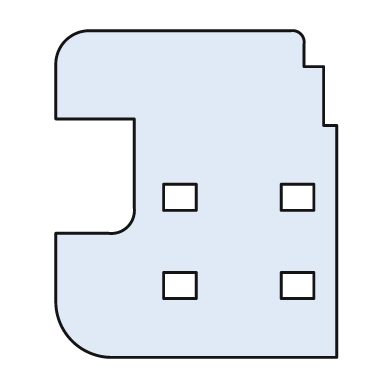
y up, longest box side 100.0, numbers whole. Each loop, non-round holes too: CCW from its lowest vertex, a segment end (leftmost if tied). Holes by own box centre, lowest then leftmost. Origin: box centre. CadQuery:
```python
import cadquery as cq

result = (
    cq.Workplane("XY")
    .moveTo(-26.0, -50.0)
    .lineTo(43.0, -50.0)
    .lineTo(43.0, 21.0)
    .lineTo(39.0, 21.0)
    .lineTo(39.0, 39.0)
    .lineTo(33.0, 39.0)
    .lineTo(33.0, 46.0)
    .threePointArc((32.0, 49.0), (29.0, 50.0))
    .lineTo(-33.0, 50.0)
    .threePointArc((-40.0, 47.0), (-43.0, 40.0))
    .lineTo(-43.0, 23.0)
    .lineTo(-19.0, 23.0)
    .lineTo(-19.0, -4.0)
    .threePointArc((-21.0, -10.0), (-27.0, -12.0))
    .lineTo(-43.0, -12.0)
    .lineTo(-43.0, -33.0)
    .threePointArc((-38.0, -45.0), (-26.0, -50.0))
    .close()
    .moveTo(-10.0, -32.0)
    .lineTo(0.0, -32.0)
    .lineTo(0.0, -24.0)
    .lineTo(-10.0, -24.0)
    .close()
    .moveTo(26.0, -32.0)
    .lineTo(36.0, -32.0)
    .lineTo(36.0, -24.0)
    .lineTo(26.0, -24.0)
    .close()
    .moveTo(-10.0, -5.0)
    .lineTo(0.0, -5.0)
    .lineTo(0.0, 3.0)
    .lineTo(-10.0, 3.0)
    .close()
    .moveTo(26.0, -5.0)
    .lineTo(36.0, -5.0)
    .lineTo(36.0, 3.0)
    .lineTo(26.0, 3.0)
    .close()
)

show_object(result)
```